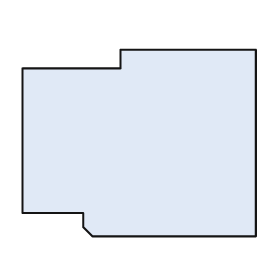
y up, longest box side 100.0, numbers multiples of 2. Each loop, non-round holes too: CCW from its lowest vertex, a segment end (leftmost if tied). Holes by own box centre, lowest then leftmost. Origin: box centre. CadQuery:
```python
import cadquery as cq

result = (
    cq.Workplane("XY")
    .moveTo(-20.0, -40.0)
    .lineTo(50.0, -40.0)
    .lineTo(50.0, 40.0)
    .lineTo(-8.0, 40.0)
    .lineTo(-8.0, 32.0)
    .lineTo(-50.0, 32.0)
    .lineTo(-50.0, -30.0)
    .lineTo(-24.0, -30.0)
    .lineTo(-24.0, -36.0)
    .close()
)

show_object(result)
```